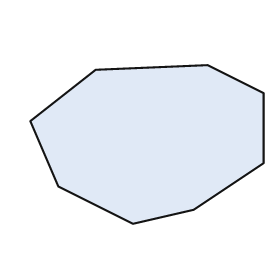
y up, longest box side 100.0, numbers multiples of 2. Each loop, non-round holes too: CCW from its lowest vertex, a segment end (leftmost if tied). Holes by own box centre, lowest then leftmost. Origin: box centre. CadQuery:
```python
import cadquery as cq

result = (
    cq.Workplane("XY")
    .moveTo(-6.0, -34.0)
    .lineTo(20.0, -28.0)
    .lineTo(50.0, -8.0)
    .lineTo(50.0, 22.0)
    .lineTo(26.0, 34.0)
    .lineTo(-22.0, 32.0)
    .lineTo(-50.0, 10.0)
    .lineTo(-38.0, -18.0)
    .close()
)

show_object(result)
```